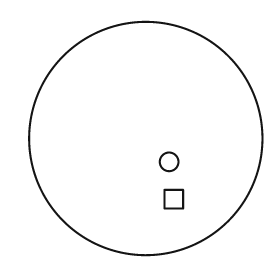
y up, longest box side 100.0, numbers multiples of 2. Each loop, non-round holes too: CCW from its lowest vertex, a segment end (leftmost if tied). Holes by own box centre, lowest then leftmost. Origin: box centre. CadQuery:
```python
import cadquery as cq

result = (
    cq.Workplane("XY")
    .moveTo(0.0, 0.0)
    .circle(50.0)
    .moveTo(8.0, -30.0)
    .lineTo(16.0, -30.0)
    .lineTo(16.0, -22.0)
    .lineTo(8.0, -22.0)
    .close()
    .moveTo(10.0, -10.0)
    .circle(4.0)
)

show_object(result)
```